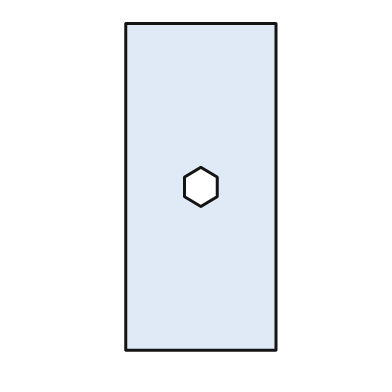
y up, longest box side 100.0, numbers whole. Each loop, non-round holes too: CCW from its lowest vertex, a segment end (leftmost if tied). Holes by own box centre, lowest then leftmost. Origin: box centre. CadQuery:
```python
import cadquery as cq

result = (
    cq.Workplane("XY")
    .moveTo(-23.0, -50.0)
    .lineTo(23.0, -50.0)
    .lineTo(23.0, 50.0)
    .lineTo(-23.0, 50.0)
    .close()
    .moveTo(0.0, -6.0)
    .lineTo(5.0, -3.0)
    .lineTo(5.0, 3.0)
    .lineTo(0.0, 6.0)
    .lineTo(-5.0, 3.0)
    .lineTo(-5.0, -3.0)
    .close()
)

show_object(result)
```